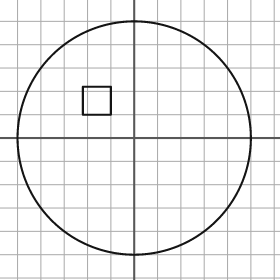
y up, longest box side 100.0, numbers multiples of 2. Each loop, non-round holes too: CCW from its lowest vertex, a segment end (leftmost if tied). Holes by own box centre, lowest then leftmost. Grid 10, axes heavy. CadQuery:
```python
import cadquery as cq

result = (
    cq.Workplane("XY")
    .moveTo(0.0, 0.0)
    .circle(50.0)
    .moveTo(-22.0, 10.0)
    .lineTo(-10.0, 10.0)
    .lineTo(-10.0, 22.0)
    .lineTo(-22.0, 22.0)
    .close()
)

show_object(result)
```